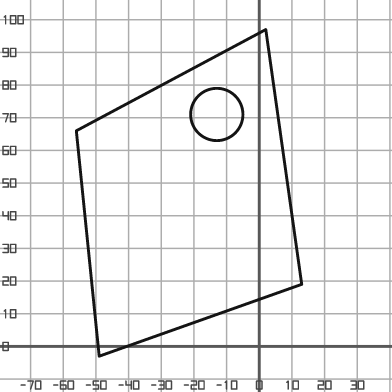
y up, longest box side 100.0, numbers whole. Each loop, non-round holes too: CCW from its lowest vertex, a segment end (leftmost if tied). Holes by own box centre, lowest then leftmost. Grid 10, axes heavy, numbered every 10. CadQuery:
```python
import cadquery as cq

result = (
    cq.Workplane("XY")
    .moveTo(-49.0, -3.0)
    .lineTo(13.0, 19.0)
    .lineTo(2.0, 97.0)
    .lineTo(-56.0, 66.0)
    .close()
    .moveTo(-13.0, 71.0)
    .circle(8.0)
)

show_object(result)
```